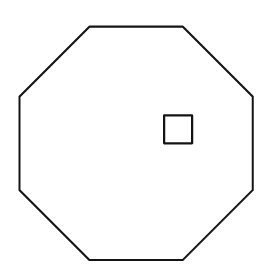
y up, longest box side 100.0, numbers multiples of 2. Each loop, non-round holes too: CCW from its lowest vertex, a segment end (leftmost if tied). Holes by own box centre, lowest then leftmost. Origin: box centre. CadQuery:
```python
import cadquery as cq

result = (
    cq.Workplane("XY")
    .moveTo(-20.0, -50.0)
    .lineTo(20.0, -50.0)
    .lineTo(50.0, -20.0)
    .lineTo(50.0, 20.0)
    .lineTo(20.0, 50.0)
    .lineTo(-20.0, 50.0)
    .lineTo(-50.0, 20.0)
    .lineTo(-50.0, -20.0)
    .close()
    .moveTo(12.0, 0.0)
    .lineTo(24.0, 0.0)
    .lineTo(24.0, 12.0)
    .lineTo(12.0, 12.0)
    .close()
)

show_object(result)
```